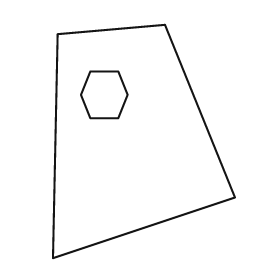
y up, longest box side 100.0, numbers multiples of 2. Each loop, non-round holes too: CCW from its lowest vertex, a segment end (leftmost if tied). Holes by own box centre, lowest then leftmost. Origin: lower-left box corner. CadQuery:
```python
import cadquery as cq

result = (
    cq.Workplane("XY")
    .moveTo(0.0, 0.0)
    .lineTo(78.0, 26.0)
    .lineTo(48.0, 100.0)
    .lineTo(2.0, 96.0)
    .close()
    .moveTo(16.0, 60.0)
    .lineTo(28.0, 60.0)
    .lineTo(32.0, 70.0)
    .lineTo(28.0, 80.0)
    .lineTo(16.0, 80.0)
    .lineTo(12.0, 70.0)
    .close()
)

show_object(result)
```